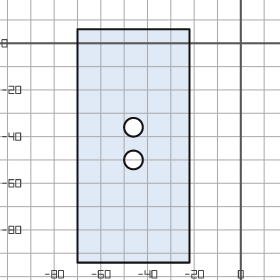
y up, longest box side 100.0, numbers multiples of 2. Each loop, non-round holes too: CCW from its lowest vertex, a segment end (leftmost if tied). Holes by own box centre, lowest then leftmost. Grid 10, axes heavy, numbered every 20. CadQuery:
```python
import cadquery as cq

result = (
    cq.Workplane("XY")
    .moveTo(-70.0, -94.0)
    .lineTo(-22.0, -94.0)
    .lineTo(-22.0, 6.0)
    .lineTo(-70.0, 6.0)
    .close()
    .moveTo(-46.0, -50.0)
    .circle(4.0)
    .moveTo(-46.0, -36.0)
    .circle(4.0)
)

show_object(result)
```